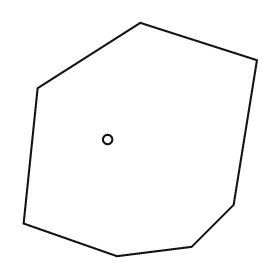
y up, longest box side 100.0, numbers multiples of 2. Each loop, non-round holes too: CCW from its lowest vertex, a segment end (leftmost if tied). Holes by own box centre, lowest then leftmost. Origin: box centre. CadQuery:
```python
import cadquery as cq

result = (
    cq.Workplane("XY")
    .moveTo(-10.0, -50.0)
    .lineTo(22.0, -46.0)
    .lineTo(40.0, -28.0)
    .lineTo(50.0, 34.0)
    .lineTo(0.0, 50.0)
    .lineTo(-44.0, 22.0)
    .lineTo(-50.0, -36.0)
    .close()
    .moveTo(-14.0, 0.0)
    .circle(2.0)
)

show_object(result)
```